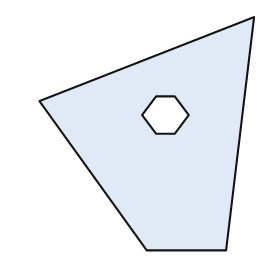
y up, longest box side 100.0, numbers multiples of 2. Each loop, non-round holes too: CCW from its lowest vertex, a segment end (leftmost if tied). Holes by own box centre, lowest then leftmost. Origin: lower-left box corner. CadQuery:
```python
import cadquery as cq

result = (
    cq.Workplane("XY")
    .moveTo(46.0, 0.0)
    .lineTo(80.0, 0.0)
    .lineTo(92.0, 100.0)
    .lineTo(0.0, 64.0)
    .close()
    .moveTo(50.0, 50.0)
    .lineTo(58.0, 50.0)
    .lineTo(64.0, 58.0)
    .lineTo(58.0, 66.0)
    .lineTo(50.0, 66.0)
    .lineTo(44.0, 58.0)
    .close()
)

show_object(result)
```